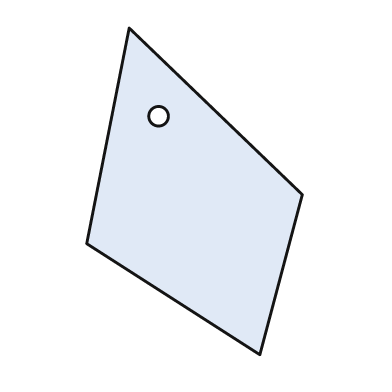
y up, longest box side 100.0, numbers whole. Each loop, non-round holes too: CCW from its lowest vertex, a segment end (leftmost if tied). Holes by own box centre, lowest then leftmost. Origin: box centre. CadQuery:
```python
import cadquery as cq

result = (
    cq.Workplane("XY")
    .moveTo(20.0, -50.0)
    .lineTo(33.0, -1.0)
    .lineTo(-20.0, 50.0)
    .lineTo(-33.0, -16.0)
    .close()
    .moveTo(-11.0, 23.0)
    .circle(3.0)
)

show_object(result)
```